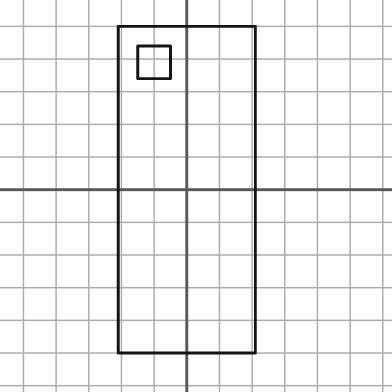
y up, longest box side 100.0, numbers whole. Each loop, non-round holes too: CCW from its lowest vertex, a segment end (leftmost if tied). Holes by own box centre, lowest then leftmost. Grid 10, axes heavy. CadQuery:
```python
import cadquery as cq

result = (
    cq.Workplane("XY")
    .moveTo(-21.0, -50.0)
    .lineTo(21.0, -50.0)
    .lineTo(21.0, 50.0)
    .lineTo(-21.0, 50.0)
    .close()
    .moveTo(-15.0, 34.0)
    .lineTo(-5.0, 34.0)
    .lineTo(-5.0, 44.0)
    .lineTo(-15.0, 44.0)
    .close()
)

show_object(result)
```